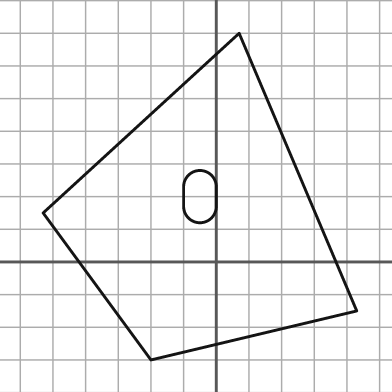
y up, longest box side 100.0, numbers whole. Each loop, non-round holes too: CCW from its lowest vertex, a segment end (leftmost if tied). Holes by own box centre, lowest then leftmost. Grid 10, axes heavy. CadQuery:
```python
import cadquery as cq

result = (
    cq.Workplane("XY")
    .moveTo(-20.0, -30.0)
    .lineTo(43.0, -15.0)
    .lineTo(7.0, 70.0)
    .lineTo(-53.0, 15.0)
    .close()
    .moveTo(-10.0, 17.0)
    .threePointArc((-5.0, 12.0), (0.0, 17.0))
    .lineTo(0.0, 23.0)
    .threePointArc((-5.0, 28.0), (-10.0, 23.0))
    .close()
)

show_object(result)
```